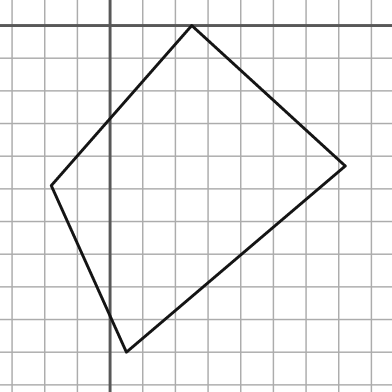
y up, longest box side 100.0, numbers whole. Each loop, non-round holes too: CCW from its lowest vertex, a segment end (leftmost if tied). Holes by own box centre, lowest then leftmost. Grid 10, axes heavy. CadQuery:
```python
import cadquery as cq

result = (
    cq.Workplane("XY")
    .moveTo(5.0, -100.0)
    .lineTo(72.0, -43.0)
    .lineTo(25.0, 0.0)
    .lineTo(-18.0, -49.0)
    .close()
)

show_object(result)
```